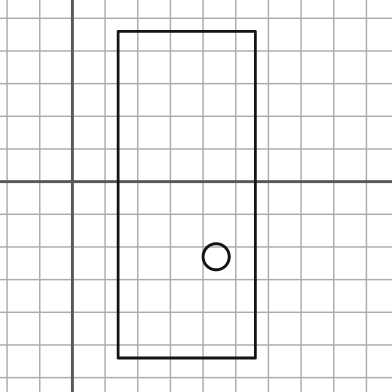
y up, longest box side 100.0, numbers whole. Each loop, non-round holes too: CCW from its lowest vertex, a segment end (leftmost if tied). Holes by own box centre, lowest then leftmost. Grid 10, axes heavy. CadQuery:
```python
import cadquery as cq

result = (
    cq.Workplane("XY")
    .moveTo(14.0, -54.0)
    .lineTo(56.0, -54.0)
    .lineTo(56.0, 46.0)
    .lineTo(14.0, 46.0)
    .close()
    .moveTo(44.0, -23.0)
    .circle(4.0)
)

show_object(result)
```